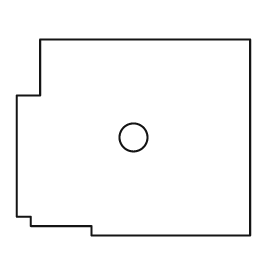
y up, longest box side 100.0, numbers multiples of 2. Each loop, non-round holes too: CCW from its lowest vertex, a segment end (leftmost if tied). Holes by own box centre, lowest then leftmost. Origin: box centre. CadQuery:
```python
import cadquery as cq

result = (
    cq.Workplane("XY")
    .moveTo(-18.0, -42.0)
    .lineTo(50.0, -42.0)
    .lineTo(50.0, 42.0)
    .lineTo(-40.0, 42.0)
    .lineTo(-40.0, 18.0)
    .lineTo(-50.0, 18.0)
    .lineTo(-50.0, -34.0)
    .lineTo(-44.0, -34.0)
    .lineTo(-44.0, -38.0)
    .lineTo(-18.0, -38.0)
    .close()
    .moveTo(0.0, 0.0)
    .circle(6.0)
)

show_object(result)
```